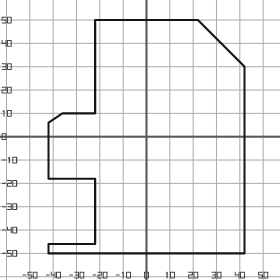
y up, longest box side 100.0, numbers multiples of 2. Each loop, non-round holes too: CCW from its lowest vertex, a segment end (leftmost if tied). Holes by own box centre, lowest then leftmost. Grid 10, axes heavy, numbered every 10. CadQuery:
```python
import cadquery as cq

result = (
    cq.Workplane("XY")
    .moveTo(-42.0, -50.0)
    .lineTo(42.0, -50.0)
    .lineTo(42.0, 30.0)
    .lineTo(22.0, 50.0)
    .lineTo(-22.0, 50.0)
    .lineTo(-22.0, 10.0)
    .lineTo(-36.0, 10.0)
    .lineTo(-42.0, 6.0)
    .lineTo(-42.0, -18.0)
    .lineTo(-22.0, -18.0)
    .lineTo(-22.0, -46.0)
    .lineTo(-42.0, -46.0)
    .close()
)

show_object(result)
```